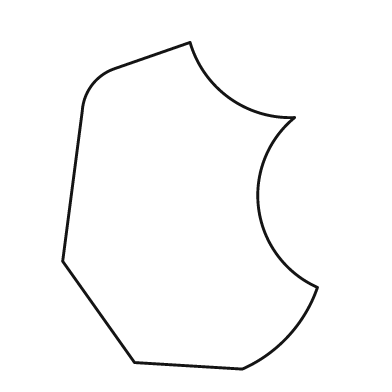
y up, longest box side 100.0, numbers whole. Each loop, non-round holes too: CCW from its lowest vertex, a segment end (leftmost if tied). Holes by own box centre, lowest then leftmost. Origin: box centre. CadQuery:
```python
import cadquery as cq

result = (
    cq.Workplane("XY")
    .moveTo(16.0, -50.0)
    .threePointArc((30.0, -40.0), (39.0, -25.0))
    .threePointArc((21.0, -1.0), (32.0, 27.0))
    .threePointArc((12.0, 33.0), (0.0, 50.0))
    .lineTo(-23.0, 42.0)
    .threePointArc((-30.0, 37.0), (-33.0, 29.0))
    .lineTo(-39.0, -17.0)
    .lineTo(-17.0, -48.0)
    .close()
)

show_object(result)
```